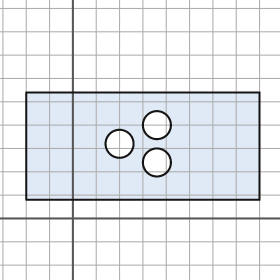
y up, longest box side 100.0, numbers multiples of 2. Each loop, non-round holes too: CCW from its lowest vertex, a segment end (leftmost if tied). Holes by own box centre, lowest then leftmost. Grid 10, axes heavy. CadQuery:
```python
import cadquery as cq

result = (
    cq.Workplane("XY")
    .moveTo(-20.0, 8.0)
    .lineTo(80.0, 8.0)
    .lineTo(80.0, 54.0)
    .lineTo(-20.0, 54.0)
    .close()
    .moveTo(36.0, 24.0)
    .circle(6.0)
    .moveTo(20.0, 32.0)
    .circle(6.0)
    .moveTo(36.0, 40.0)
    .circle(6.0)
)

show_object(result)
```